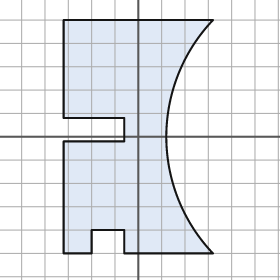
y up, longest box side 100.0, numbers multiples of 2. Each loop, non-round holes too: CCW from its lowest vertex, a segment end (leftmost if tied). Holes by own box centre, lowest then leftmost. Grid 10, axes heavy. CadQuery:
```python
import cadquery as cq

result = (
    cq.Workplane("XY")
    .moveTo(-32.0, -50.0)
    .lineTo(-20.0, -50.0)
    .lineTo(-20.0, -40.0)
    .lineTo(-6.0, -40.0)
    .lineTo(-6.0, -50.0)
    .lineTo(32.0, -50.0)
    .threePointArc((12.0, 0.0), (32.0, 50.0))
    .lineTo(-32.0, 50.0)
    .lineTo(-32.0, 8.0)
    .lineTo(-6.0, 8.0)
    .lineTo(-6.0, -2.0)
    .lineTo(-32.0, -2.0)
    .close()
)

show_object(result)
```